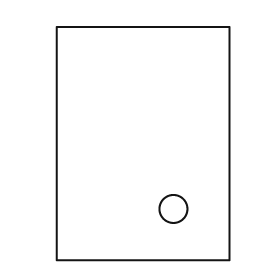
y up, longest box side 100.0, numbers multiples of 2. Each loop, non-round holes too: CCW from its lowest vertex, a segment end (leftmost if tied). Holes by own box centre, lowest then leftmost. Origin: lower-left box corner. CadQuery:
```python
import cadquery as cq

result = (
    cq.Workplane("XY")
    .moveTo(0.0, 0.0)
    .lineTo(74.0, 0.0)
    .lineTo(74.0, 100.0)
    .lineTo(0.0, 100.0)
    .close()
    .moveTo(50.0, 22.0)
    .circle(6.0)
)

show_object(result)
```